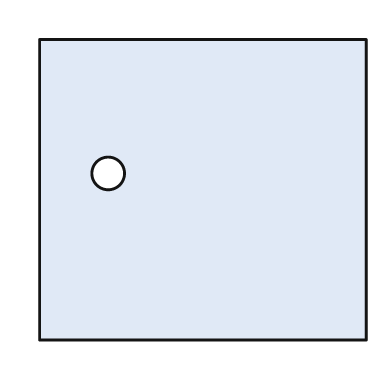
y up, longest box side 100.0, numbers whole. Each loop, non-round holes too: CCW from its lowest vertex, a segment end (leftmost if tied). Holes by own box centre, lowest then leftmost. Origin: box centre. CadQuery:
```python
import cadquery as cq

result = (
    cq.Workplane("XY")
    .moveTo(-50.0, -46.0)
    .lineTo(50.0, -46.0)
    .lineTo(50.0, 46.0)
    .lineTo(-50.0, 46.0)
    .close()
    .moveTo(-29.0, 5.0)
    .circle(5.0)
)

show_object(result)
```